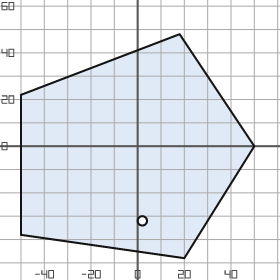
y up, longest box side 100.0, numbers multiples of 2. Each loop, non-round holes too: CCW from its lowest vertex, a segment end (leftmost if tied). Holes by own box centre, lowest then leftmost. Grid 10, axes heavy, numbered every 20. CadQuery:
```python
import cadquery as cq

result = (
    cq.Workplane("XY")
    .moveTo(20.0, -48.0)
    .lineTo(50.0, 0.0)
    .lineTo(18.0, 48.0)
    .lineTo(-50.0, 22.0)
    .lineTo(-50.0, -38.0)
    .close()
    .moveTo(2.0, -32.0)
    .circle(2.0)
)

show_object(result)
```